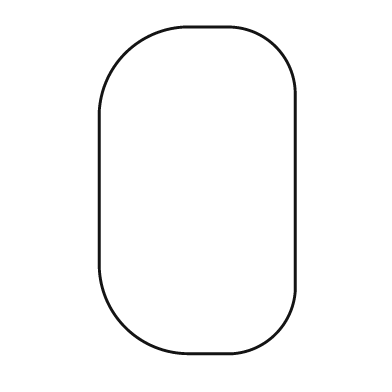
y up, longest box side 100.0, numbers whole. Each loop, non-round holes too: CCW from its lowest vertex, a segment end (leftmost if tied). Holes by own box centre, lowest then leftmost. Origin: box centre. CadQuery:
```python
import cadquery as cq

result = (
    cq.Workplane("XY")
    .moveTo(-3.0, -50.0)
    .lineTo(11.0, -50.0)
    .threePointArc((24.0, -44.0), (30.0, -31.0))
    .lineTo(30.0, 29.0)
    .threePointArc((24.0, 44.0), (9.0, 50.0))
    .lineTo(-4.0, 50.0)
    .threePointArc((-22.0, 42.0), (-30.0, 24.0))
    .lineTo(-30.0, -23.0)
    .threePointArc((-22.0, -42.0), (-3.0, -50.0))
    .close()
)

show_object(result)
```